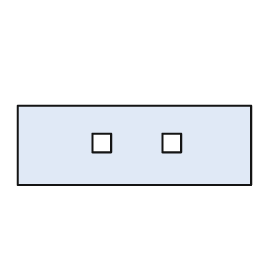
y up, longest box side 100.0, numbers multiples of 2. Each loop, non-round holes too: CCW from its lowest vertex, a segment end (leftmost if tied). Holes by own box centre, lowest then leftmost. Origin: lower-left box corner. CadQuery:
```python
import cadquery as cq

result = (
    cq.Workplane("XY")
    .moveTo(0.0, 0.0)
    .lineTo(100.0, 0.0)
    .lineTo(100.0, 34.0)
    .lineTo(0.0, 34.0)
    .close()
    .moveTo(32.0, 14.0)
    .lineTo(40.0, 14.0)
    .lineTo(40.0, 22.0)
    .lineTo(32.0, 22.0)
    .close()
    .moveTo(62.0, 14.0)
    .lineTo(70.0, 14.0)
    .lineTo(70.0, 22.0)
    .lineTo(62.0, 22.0)
    .close()
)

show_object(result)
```